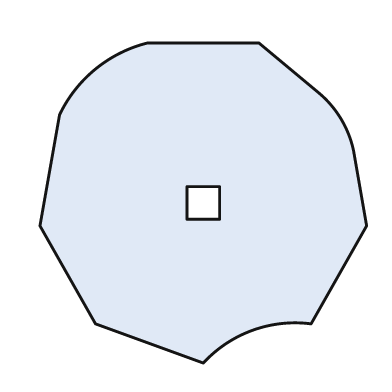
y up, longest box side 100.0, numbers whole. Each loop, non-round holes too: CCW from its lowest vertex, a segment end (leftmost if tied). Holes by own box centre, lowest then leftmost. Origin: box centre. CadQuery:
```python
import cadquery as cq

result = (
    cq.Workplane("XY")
    .moveTo(0.0, -49.0)
    .threePointArc((15.0, -39.0), (33.0, -37.0))
    .lineTo(50.0, -7.0)
    .lineTo(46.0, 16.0)
    .threePointArc((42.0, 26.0), (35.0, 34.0))
    .lineTo(17.0, 49.0)
    .lineTo(-17.0, 49.0)
    .threePointArc((-33.0, 41.0), (-44.0, 27.0))
    .lineTo(-50.0, -7.0)
    .lineTo(-33.0, -37.0)
    .close()
    .moveTo(-5.0, -5.0)
    .lineTo(5.0, -5.0)
    .lineTo(5.0, 5.0)
    .lineTo(-5.0, 5.0)
    .close()
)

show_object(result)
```